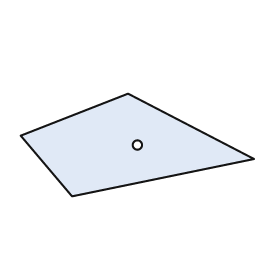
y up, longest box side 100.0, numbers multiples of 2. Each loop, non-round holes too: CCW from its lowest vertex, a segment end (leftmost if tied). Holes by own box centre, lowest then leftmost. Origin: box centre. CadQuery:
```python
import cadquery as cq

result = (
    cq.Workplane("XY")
    .moveTo(-28.0, -22.0)
    .lineTo(50.0, -6.0)
    .lineTo(-4.0, 22.0)
    .lineTo(-50.0, 4.0)
    .close()
    .moveTo(0.0, 0.0)
    .circle(2.0)
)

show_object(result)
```